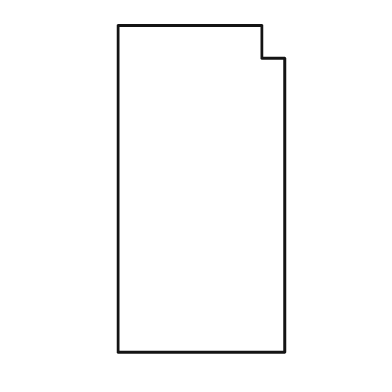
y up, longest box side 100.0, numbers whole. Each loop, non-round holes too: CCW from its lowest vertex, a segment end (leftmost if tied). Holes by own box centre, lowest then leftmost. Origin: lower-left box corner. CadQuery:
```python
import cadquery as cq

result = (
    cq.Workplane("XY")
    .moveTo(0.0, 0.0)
    .lineTo(51.0, 0.0)
    .lineTo(51.0, 90.0)
    .lineTo(44.0, 90.0)
    .lineTo(44.0, 100.0)
    .lineTo(0.0, 100.0)
    .close()
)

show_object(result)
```